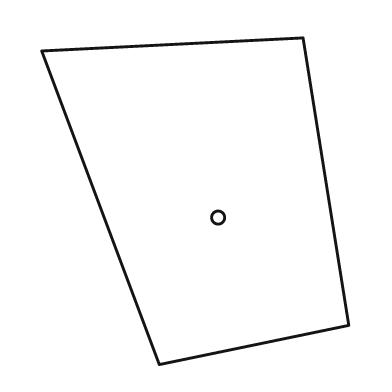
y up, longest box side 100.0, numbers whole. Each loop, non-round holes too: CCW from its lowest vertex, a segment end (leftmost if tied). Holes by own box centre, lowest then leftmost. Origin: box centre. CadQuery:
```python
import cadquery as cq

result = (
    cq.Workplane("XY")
    .moveTo(-11.0, -50.0)
    .lineTo(47.0, -38.0)
    .lineTo(33.0, 50.0)
    .lineTo(-47.0, 46.0)
    .close()
    .moveTo(7.0, -5.0)
    .circle(2.0)
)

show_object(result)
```